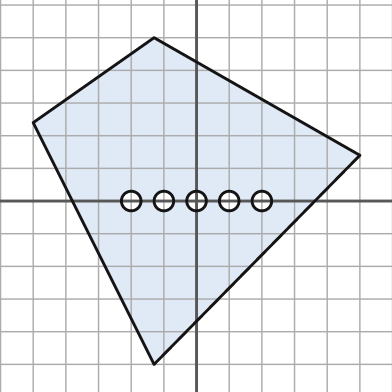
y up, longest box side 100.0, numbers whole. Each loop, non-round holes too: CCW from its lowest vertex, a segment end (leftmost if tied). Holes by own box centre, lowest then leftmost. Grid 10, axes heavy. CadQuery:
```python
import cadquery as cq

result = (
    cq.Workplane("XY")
    .moveTo(-13.0, -50.0)
    .lineTo(50.0, 14.0)
    .lineTo(-13.0, 50.0)
    .lineTo(-50.0, 24.0)
    .close()
    .moveTo(-20.0, 0.0)
    .circle(3.0)
    .moveTo(-10.0, 0.0)
    .circle(3.0)
    .moveTo(0.0, 0.0)
    .circle(3.0)
    .moveTo(10.0, 0.0)
    .circle(3.0)
    .moveTo(20.0, 0.0)
    .circle(3.0)
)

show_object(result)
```